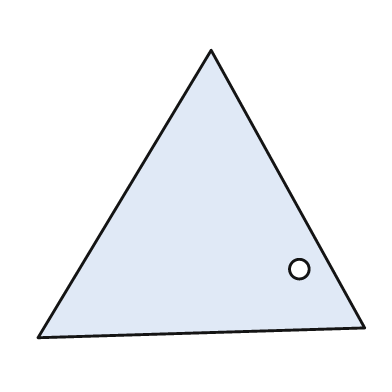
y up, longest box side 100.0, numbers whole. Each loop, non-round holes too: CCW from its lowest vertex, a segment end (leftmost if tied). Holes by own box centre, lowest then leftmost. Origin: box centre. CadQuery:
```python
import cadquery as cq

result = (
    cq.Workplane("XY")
    .moveTo(-50.0, -44.0)
    .lineTo(50.0, -41.0)
    .lineTo(3.0, 44.0)
    .close()
    .moveTo(30.0, -23.0)
    .circle(3.0)
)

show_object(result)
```